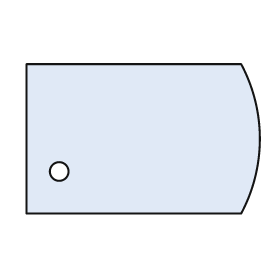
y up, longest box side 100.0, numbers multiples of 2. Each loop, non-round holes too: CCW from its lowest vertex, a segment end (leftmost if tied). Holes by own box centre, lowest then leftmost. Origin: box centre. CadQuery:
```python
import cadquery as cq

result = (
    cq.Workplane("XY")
    .moveTo(-50.0, -32.0)
    .lineTo(42.0, -32.0)
    .threePointArc((50.0, 0.0), (42.0, 32.0))
    .lineTo(-50.0, 32.0)
    .close()
    .moveTo(-36.0, -14.0)
    .circle(4.0)
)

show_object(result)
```